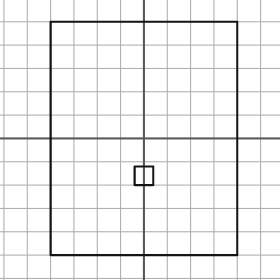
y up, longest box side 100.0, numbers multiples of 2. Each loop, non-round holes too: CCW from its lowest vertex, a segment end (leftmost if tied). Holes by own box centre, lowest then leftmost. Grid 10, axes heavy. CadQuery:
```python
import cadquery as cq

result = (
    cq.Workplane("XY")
    .moveTo(-40.0, -50.0)
    .lineTo(40.0, -50.0)
    .lineTo(40.0, 50.0)
    .lineTo(-40.0, 50.0)
    .close()
    .moveTo(-4.0, -20.0)
    .lineTo(4.0, -20.0)
    .lineTo(4.0, -12.0)
    .lineTo(-4.0, -12.0)
    .close()
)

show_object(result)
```